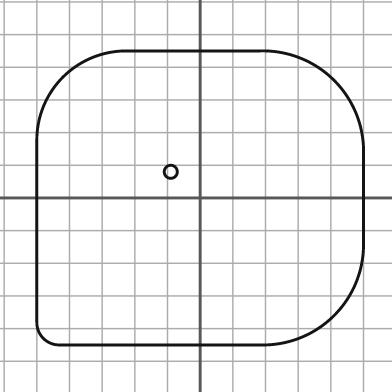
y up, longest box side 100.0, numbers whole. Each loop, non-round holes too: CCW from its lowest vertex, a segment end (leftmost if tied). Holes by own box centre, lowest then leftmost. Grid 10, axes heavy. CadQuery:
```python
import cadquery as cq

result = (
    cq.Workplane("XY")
    .moveTo(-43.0, -45.0)
    .lineTo(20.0, -45.0)
    .threePointArc((41.0, -36.0), (50.0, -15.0))
    .lineTo(50.0, 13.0)
    .threePointArc((41.0, 36.0), (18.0, 45.0))
    .lineTo(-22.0, 45.0)
    .threePointArc((-42.0, 37.0), (-50.0, 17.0))
    .lineTo(-50.0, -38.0)
    .threePointArc((-48.0, -43.0), (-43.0, -45.0))
    .close()
    .moveTo(-9.0, 8.0)
    .circle(2.0)
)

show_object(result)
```